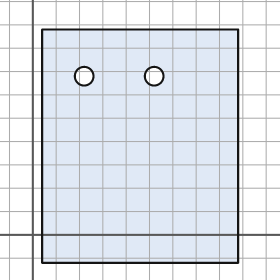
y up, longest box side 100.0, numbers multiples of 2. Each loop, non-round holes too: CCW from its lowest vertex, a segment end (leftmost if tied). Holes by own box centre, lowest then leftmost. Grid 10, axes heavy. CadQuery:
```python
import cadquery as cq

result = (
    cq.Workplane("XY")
    .moveTo(4.0, -12.0)
    .lineTo(88.0, -12.0)
    .lineTo(88.0, 88.0)
    .lineTo(4.0, 88.0)
    .close()
    .moveTo(22.0, 68.0)
    .circle(4.0)
    .moveTo(52.0, 68.0)
    .circle(4.0)
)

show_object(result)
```